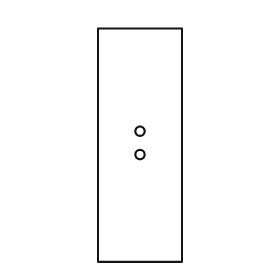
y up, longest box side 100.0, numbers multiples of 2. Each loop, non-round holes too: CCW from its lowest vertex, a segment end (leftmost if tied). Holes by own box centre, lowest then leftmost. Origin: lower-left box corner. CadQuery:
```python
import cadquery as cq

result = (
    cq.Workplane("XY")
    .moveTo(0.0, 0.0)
    .lineTo(36.0, 0.0)
    .lineTo(36.0, 100.0)
    .lineTo(0.0, 100.0)
    .close()
    .moveTo(18.0, 46.0)
    .circle(2.0)
    .moveTo(18.0, 56.0)
    .circle(2.0)
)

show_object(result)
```